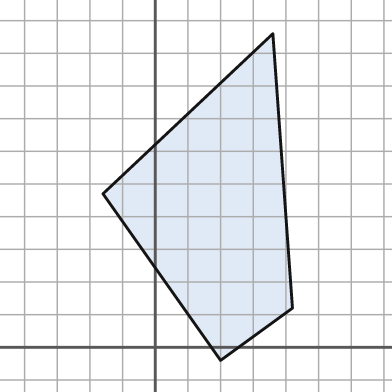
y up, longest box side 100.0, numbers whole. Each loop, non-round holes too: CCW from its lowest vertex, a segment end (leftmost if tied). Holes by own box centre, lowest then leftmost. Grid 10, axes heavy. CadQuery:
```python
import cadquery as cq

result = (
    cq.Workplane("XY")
    .moveTo(20.0, -4.0)
    .lineTo(42.0, 12.0)
    .lineTo(36.0, 96.0)
    .lineTo(-16.0, 47.0)
    .close()
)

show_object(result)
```